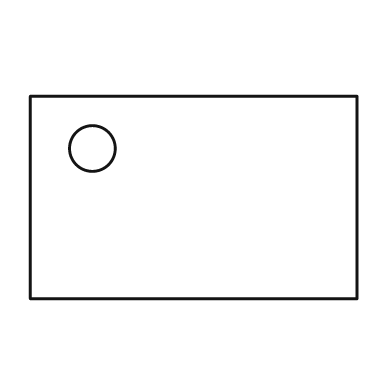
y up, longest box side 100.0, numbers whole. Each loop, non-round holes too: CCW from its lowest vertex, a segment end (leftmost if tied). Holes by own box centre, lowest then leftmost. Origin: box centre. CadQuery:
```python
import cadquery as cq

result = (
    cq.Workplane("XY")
    .moveTo(-50.0, -31.0)
    .lineTo(50.0, -31.0)
    .lineTo(50.0, 31.0)
    .lineTo(-50.0, 31.0)
    .close()
    .moveTo(-31.0, 15.0)
    .circle(7.0)
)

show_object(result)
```